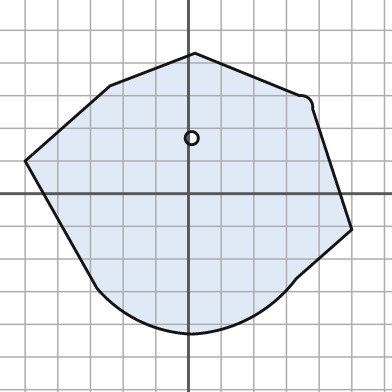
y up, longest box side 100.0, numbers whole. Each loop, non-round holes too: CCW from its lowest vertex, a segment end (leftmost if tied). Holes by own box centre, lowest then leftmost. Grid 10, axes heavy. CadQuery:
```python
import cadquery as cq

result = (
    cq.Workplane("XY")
    .moveTo(1.0, -43.0)
    .threePointArc((19.0, -38.0), (33.0, -26.0))
    .lineTo(50.0, -11.0)
    .lineTo(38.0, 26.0)
    .threePointArc((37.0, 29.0), (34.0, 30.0))
    .lineTo(2.0, 43.0)
    .lineTo(-24.0, 33.0)
    .lineTo(-50.0, 10.0)
    .lineTo(-28.0, -29.0)
    .threePointArc((-15.0, -39.0), (1.0, -43.0))
    .close()
    .moveTo(1.0, 17.0)
    .circle(2.0)
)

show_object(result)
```